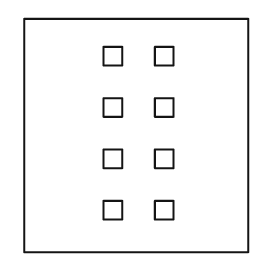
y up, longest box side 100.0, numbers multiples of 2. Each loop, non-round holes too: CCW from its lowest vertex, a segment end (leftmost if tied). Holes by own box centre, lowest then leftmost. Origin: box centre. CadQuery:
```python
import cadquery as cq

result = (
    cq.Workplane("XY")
    .moveTo(-48.0, -50.0)
    .lineTo(48.0, -50.0)
    .lineTo(48.0, 50.0)
    .lineTo(-48.0, 50.0)
    .close()
    .moveTo(-14.0, -36.0)
    .lineTo(-6.0, -36.0)
    .lineTo(-6.0, -28.0)
    .lineTo(-14.0, -28.0)
    .close()
    .moveTo(8.0, -36.0)
    .lineTo(16.0, -36.0)
    .lineTo(16.0, -28.0)
    .lineTo(8.0, -28.0)
    .close()
    .moveTo(-14.0, -14.0)
    .lineTo(-6.0, -14.0)
    .lineTo(-6.0, -6.0)
    .lineTo(-14.0, -6.0)
    .close()
    .moveTo(8.0, -14.0)
    .lineTo(16.0, -14.0)
    .lineTo(16.0, -6.0)
    .lineTo(8.0, -6.0)
    .close()
    .moveTo(-14.0, 8.0)
    .lineTo(-6.0, 8.0)
    .lineTo(-6.0, 16.0)
    .lineTo(-14.0, 16.0)
    .close()
    .moveTo(8.0, 8.0)
    .lineTo(16.0, 8.0)
    .lineTo(16.0, 16.0)
    .lineTo(8.0, 16.0)
    .close()
    .moveTo(-14.0, 30.0)
    .lineTo(-6.0, 30.0)
    .lineTo(-6.0, 38.0)
    .lineTo(-14.0, 38.0)
    .close()
    .moveTo(8.0, 30.0)
    .lineTo(16.0, 30.0)
    .lineTo(16.0, 38.0)
    .lineTo(8.0, 38.0)
    .close()
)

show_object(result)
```